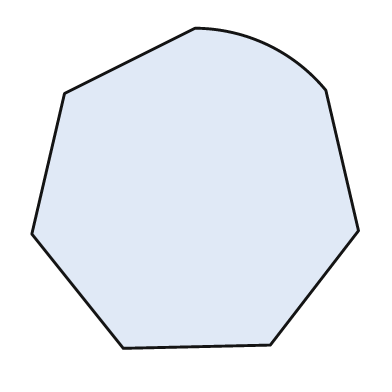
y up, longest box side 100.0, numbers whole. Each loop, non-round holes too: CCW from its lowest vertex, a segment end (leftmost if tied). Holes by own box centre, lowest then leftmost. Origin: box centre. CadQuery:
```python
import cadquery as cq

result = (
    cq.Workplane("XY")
    .moveTo(-22.0, -49.0)
    .lineTo(23.0, -48.0)
    .lineTo(50.0, -13.0)
    .lineTo(40.0, 30.0)
    .threePointArc((22.0, 44.0), (0.0, 49.0))
    .lineTo(-40.0, 29.0)
    .lineTo(-50.0, -14.0)
    .close()
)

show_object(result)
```